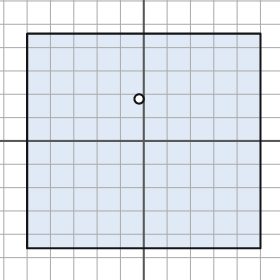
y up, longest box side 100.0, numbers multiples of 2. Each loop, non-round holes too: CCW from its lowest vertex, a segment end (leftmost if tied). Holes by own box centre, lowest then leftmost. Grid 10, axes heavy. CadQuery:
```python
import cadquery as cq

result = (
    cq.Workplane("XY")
    .moveTo(-50.0, -46.0)
    .lineTo(50.0, -46.0)
    .lineTo(50.0, 46.0)
    .lineTo(-50.0, 46.0)
    .close()
    .moveTo(-2.0, 18.0)
    .circle(2.0)
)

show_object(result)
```